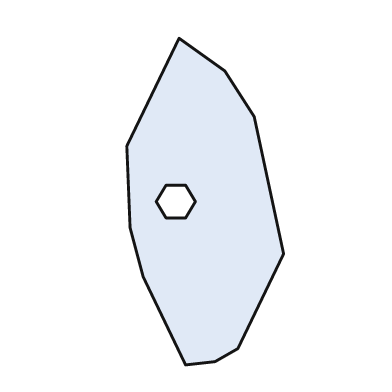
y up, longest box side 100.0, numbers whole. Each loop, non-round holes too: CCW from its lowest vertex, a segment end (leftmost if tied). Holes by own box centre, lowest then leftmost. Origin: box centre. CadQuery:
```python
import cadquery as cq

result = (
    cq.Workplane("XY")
    .moveTo(-6.0, -50.0)
    .lineTo(3.0, -49.0)
    .lineTo(10.0, -45.0)
    .lineTo(24.0, -16.0)
    .lineTo(15.0, 26.0)
    .lineTo(6.0, 40.0)
    .lineTo(-8.0, 50.0)
    .lineTo(-24.0, 17.0)
    .lineTo(-23.0, -8.0)
    .lineTo(-19.0, -23.0)
    .close()
    .moveTo(-12.0, -5.0)
    .lineTo(-6.0, -5.0)
    .lineTo(-3.0, 0.0)
    .lineTo(-6.0, 5.0)
    .lineTo(-12.0, 5.0)
    .lineTo(-15.0, 0.0)
    .close()
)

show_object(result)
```